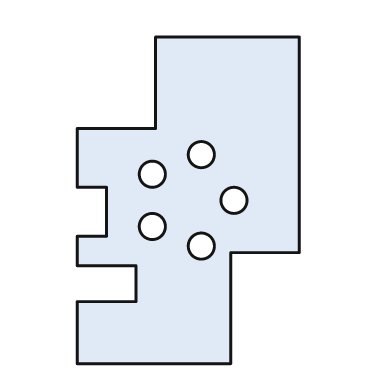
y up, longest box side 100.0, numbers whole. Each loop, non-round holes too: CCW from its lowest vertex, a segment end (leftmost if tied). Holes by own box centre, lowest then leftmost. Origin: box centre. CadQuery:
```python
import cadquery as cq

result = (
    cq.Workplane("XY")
    .moveTo(-34.0, -50.0)
    .lineTo(13.0, -50.0)
    .lineTo(13.0, -16.0)
    .lineTo(34.0, -16.0)
    .lineTo(34.0, 50.0)
    .lineTo(-10.0, 50.0)
    .lineTo(-10.0, 22.0)
    .lineTo(-34.0, 22.0)
    .lineTo(-34.0, 4.0)
    .lineTo(-25.0, 4.0)
    .lineTo(-25.0, -11.0)
    .lineTo(-34.0, -11.0)
    .lineTo(-34.0, -20.0)
    .lineTo(-16.0, -20.0)
    .lineTo(-16.0, -31.0)
    .lineTo(-34.0, -31.0)
    .close()
    .moveTo(4.0, -14.0)
    .circle(4.0)
    .moveTo(-11.0, -8.0)
    .circle(4.0)
    .moveTo(14.0, 0.0)
    .circle(4.0)
    .moveTo(-11.0, 8.0)
    .circle(4.0)
    .moveTo(4.0, 14.0)
    .circle(4.0)
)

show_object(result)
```